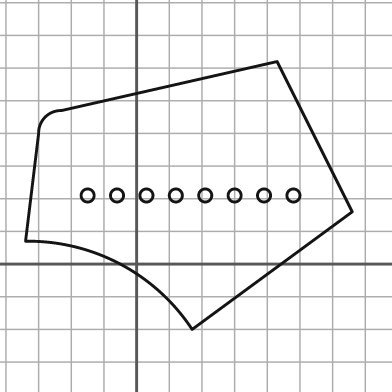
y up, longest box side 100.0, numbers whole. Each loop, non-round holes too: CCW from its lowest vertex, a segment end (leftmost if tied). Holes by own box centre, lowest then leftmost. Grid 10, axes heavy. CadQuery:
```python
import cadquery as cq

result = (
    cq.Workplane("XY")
    .moveTo(17.0, -20.0)
    .lineTo(66.0, 16.0)
    .lineTo(43.0, 62.0)
    .lineTo(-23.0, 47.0)
    .threePointArc((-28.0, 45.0), (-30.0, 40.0))
    .lineTo(-34.0, 7.0)
    .threePointArc((-5.0, 0.0), (17.0, -20.0))
    .close()
    .moveTo(-15.0, 21.0)
    .circle(2.0)
    .moveTo(-6.0, 21.0)
    .circle(2.0)
    .moveTo(3.0, 21.0)
    .circle(2.0)
    .moveTo(12.0, 21.0)
    .circle(2.0)
    .moveTo(21.0, 21.0)
    .circle(2.0)
    .moveTo(30.0, 21.0)
    .circle(2.0)
    .moveTo(39.0, 21.0)
    .circle(2.0)
    .moveTo(48.0, 21.0)
    .circle(2.0)
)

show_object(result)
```